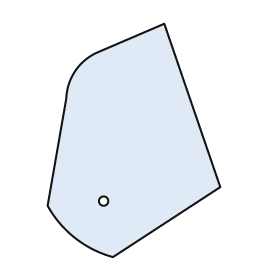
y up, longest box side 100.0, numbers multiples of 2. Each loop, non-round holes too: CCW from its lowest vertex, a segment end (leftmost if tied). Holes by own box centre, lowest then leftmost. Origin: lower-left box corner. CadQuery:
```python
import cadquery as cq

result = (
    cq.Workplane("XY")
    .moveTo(28.0, 0.0)
    .lineTo(74.0, 30.0)
    .lineTo(50.0, 100.0)
    .lineTo(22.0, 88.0)
    .threePointArc((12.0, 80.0), (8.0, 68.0))
    .lineTo(0.0, 22.0)
    .threePointArc((12.0, 8.0), (28.0, 0.0))
    .close()
    .moveTo(24.0, 24.0)
    .circle(2.0)
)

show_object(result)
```